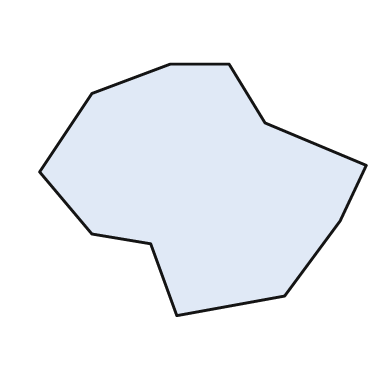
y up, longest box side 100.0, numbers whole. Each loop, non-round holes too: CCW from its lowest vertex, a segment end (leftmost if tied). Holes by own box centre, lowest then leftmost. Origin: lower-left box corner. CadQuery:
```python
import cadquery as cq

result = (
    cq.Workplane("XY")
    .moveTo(42.0, 0.0)
    .lineTo(75.0, 6.0)
    .lineTo(92.0, 29.0)
    .lineTo(100.0, 46.0)
    .lineTo(69.0, 59.0)
    .lineTo(58.0, 77.0)
    .lineTo(40.0, 77.0)
    .lineTo(16.0, 68.0)
    .lineTo(0.0, 44.0)
    .lineTo(16.0, 25.0)
    .lineTo(34.0, 22.0)
    .close()
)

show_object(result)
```